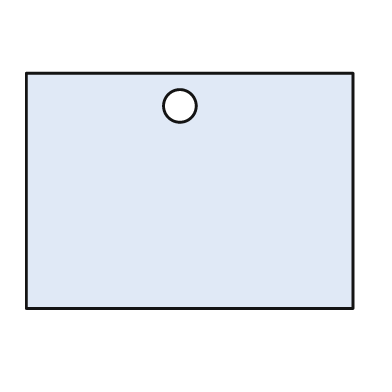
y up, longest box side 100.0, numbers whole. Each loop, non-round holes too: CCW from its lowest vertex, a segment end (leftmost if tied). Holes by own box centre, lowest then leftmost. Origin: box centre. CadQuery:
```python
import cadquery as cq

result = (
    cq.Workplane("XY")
    .moveTo(-50.0, -36.0)
    .lineTo(50.0, -36.0)
    .lineTo(50.0, 36.0)
    .lineTo(-50.0, 36.0)
    .close()
    .moveTo(-3.0, 26.0)
    .circle(5.0)
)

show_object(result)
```